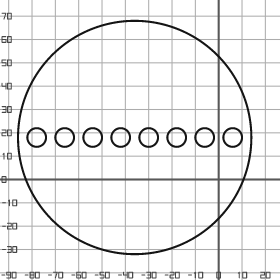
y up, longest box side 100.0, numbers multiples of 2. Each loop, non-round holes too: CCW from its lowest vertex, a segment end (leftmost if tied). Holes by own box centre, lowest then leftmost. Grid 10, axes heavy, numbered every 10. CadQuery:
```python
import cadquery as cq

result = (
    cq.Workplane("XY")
    .moveTo(-36.0, 18.0)
    .circle(50.0)
    .moveTo(-78.0, 18.0)
    .circle(4.0)
    .moveTo(-66.0, 18.0)
    .circle(4.0)
    .moveTo(-54.0, 18.0)
    .circle(4.0)
    .moveTo(-42.0, 18.0)
    .circle(4.0)
    .moveTo(-30.0, 18.0)
    .circle(4.0)
    .moveTo(-18.0, 18.0)
    .circle(4.0)
    .moveTo(-6.0, 18.0)
    .circle(4.0)
    .moveTo(6.0, 18.0)
    .circle(4.0)
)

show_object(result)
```